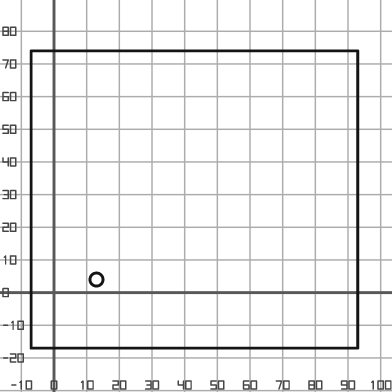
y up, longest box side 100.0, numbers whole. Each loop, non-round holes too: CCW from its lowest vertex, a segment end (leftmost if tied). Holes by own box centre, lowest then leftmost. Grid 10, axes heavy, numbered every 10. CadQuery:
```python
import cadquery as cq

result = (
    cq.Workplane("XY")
    .moveTo(-7.0, -17.0)
    .lineTo(93.0, -17.0)
    .lineTo(93.0, 74.0)
    .lineTo(-7.0, 74.0)
    .close()
    .moveTo(13.0, 4.0)
    .circle(2.0)
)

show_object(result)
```